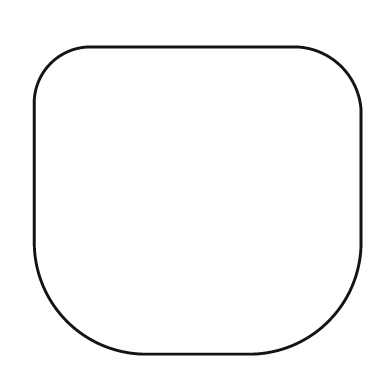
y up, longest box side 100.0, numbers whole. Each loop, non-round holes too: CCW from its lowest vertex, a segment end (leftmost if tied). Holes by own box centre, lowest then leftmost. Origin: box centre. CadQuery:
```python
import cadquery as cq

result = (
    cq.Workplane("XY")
    .moveTo(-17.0, -47.0)
    .lineTo(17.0, -47.0)
    .threePointArc((40.0, -37.0), (50.0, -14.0))
    .lineTo(50.0, 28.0)
    .threePointArc((44.0, 41.0), (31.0, 47.0))
    .lineTo(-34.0, 47.0)
    .threePointArc((-45.0, 42.0), (-50.0, 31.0))
    .lineTo(-50.0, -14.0)
    .threePointArc((-40.0, -37.0), (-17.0, -47.0))
    .close()
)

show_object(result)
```